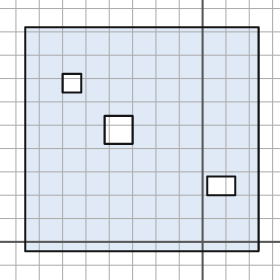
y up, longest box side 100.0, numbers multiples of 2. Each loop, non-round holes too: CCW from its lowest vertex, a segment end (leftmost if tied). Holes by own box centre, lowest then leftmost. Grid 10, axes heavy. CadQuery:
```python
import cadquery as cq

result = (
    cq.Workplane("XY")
    .moveTo(-76.0, -4.0)
    .lineTo(24.0, -4.0)
    .lineTo(24.0, 92.0)
    .lineTo(-76.0, 92.0)
    .close()
    .moveTo(2.0, 20.0)
    .lineTo(14.0, 20.0)
    .lineTo(14.0, 28.0)
    .lineTo(2.0, 28.0)
    .close()
    .moveTo(-42.0, 42.0)
    .lineTo(-30.0, 42.0)
    .lineTo(-30.0, 54.0)
    .lineTo(-42.0, 54.0)
    .close()
    .moveTo(-60.0, 64.0)
    .lineTo(-52.0, 64.0)
    .lineTo(-52.0, 72.0)
    .lineTo(-60.0, 72.0)
    .close()
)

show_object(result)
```